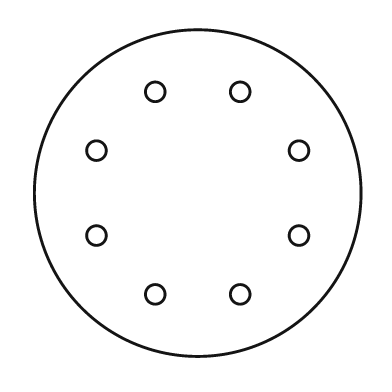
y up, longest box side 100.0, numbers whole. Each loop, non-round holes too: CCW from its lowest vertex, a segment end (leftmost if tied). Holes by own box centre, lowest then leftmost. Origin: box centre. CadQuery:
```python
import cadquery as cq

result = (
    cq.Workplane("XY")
    .moveTo(0.0, 0.0)
    .circle(50.0)
    .moveTo(-13.0, -31.0)
    .circle(3.0)
    .moveTo(13.0, -31.0)
    .circle(3.0)
    .moveTo(-31.0, -13.0)
    .circle(3.0)
    .moveTo(31.0, -13.0)
    .circle(3.0)
    .moveTo(-31.0, 13.0)
    .circle(3.0)
    .moveTo(31.0, 13.0)
    .circle(3.0)
    .moveTo(-13.0, 31.0)
    .circle(3.0)
    .moveTo(13.0, 31.0)
    .circle(3.0)
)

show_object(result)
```